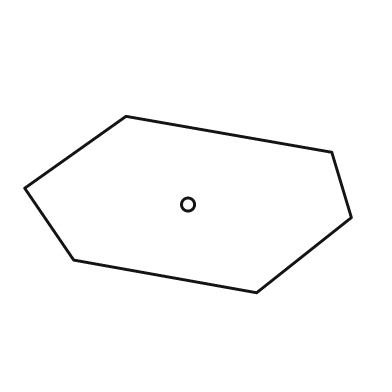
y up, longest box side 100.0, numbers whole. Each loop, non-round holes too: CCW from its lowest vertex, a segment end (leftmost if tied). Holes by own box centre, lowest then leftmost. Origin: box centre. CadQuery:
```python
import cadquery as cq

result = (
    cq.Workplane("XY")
    .moveTo(21.0, -27.0)
    .lineTo(50.0, -4.0)
    .lineTo(44.0, 16.0)
    .lineTo(-19.0, 27.0)
    .lineTo(-50.0, 5.0)
    .lineTo(-35.0, -17.0)
    .close()
    .moveTo(0.0, 0.0)
    .circle(2.0)
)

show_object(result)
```